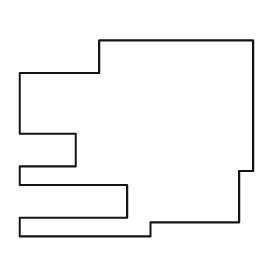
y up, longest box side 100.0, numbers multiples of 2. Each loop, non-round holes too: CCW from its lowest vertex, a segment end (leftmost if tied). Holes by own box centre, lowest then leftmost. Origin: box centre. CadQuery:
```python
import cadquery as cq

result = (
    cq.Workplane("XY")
    .moveTo(-50.0, -42.0)
    .lineTo(6.0, -42.0)
    .lineTo(6.0, -36.0)
    .lineTo(44.0, -36.0)
    .lineTo(44.0, -14.0)
    .lineTo(50.0, -14.0)
    .lineTo(50.0, 42.0)
    .lineTo(-16.0, 42.0)
    .lineTo(-16.0, 28.0)
    .lineTo(-50.0, 28.0)
    .lineTo(-50.0, 2.0)
    .lineTo(-26.0, 2.0)
    .lineTo(-26.0, -12.0)
    .lineTo(-50.0, -12.0)
    .lineTo(-50.0, -20.0)
    .lineTo(-4.0, -20.0)
    .lineTo(-4.0, -34.0)
    .lineTo(-50.0, -34.0)
    .close()
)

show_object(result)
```